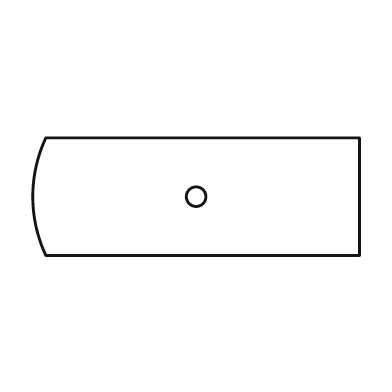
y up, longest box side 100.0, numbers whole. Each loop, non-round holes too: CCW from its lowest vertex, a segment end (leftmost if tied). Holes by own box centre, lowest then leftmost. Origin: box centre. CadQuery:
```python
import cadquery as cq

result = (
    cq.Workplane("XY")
    .moveTo(-46.0, -18.0)
    .lineTo(50.0, -18.0)
    .lineTo(50.0, 18.0)
    .lineTo(-46.0, 18.0)
    .threePointArc((-50.0, 0.0), (-46.0, -18.0))
    .close()
    .moveTo(0.0, 0.0)
    .circle(3.0)
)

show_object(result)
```